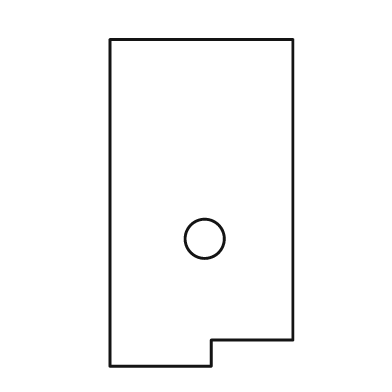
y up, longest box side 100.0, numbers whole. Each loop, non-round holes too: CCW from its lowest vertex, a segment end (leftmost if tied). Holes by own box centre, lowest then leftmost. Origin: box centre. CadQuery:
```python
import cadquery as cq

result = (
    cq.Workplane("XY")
    .moveTo(-28.0, -50.0)
    .lineTo(3.0, -50.0)
    .lineTo(3.0, -42.0)
    .lineTo(28.0, -42.0)
    .lineTo(28.0, 50.0)
    .lineTo(-28.0, 50.0)
    .close()
    .moveTo(1.0, -11.0)
    .circle(6.0)
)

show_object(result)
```